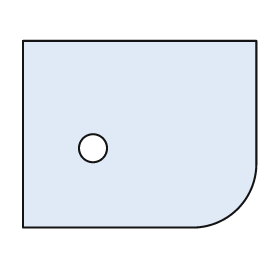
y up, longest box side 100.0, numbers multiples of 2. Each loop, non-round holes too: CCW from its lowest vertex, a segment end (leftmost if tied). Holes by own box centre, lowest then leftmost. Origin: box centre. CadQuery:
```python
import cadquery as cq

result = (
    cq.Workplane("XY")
    .moveTo(-50.0, -40.0)
    .lineTo(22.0, -40.0)
    .threePointArc((42.0, -32.0), (50.0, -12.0))
    .lineTo(50.0, 40.0)
    .lineTo(-50.0, 40.0)
    .close()
    .moveTo(-20.0, -6.0)
    .circle(6.0)
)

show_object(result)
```